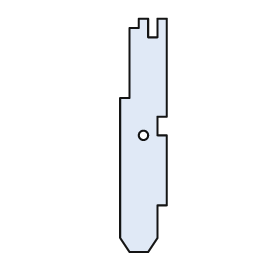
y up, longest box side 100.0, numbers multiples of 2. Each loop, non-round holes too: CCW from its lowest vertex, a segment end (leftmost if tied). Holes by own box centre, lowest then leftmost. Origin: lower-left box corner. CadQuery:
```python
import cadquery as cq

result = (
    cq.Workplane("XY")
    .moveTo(4.0, 0.0)
    .lineTo(12.0, 0.0)
    .lineTo(16.0, 6.0)
    .lineTo(16.0, 20.0)
    .lineTo(20.0, 20.0)
    .lineTo(20.0, 50.0)
    .lineTo(16.0, 50.0)
    .lineTo(16.0, 58.0)
    .lineTo(20.0, 58.0)
    .lineTo(20.0, 100.0)
    .lineTo(16.0, 100.0)
    .lineTo(16.0, 92.0)
    .lineTo(12.0, 92.0)
    .lineTo(12.0, 100.0)
    .lineTo(8.0, 100.0)
    .lineTo(8.0, 96.0)
    .lineTo(4.0, 96.0)
    .lineTo(4.0, 66.0)
    .lineTo(0.0, 66.0)
    .lineTo(0.0, 6.0)
    .close()
    .moveTo(10.0, 50.0)
    .circle(2.0)
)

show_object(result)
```